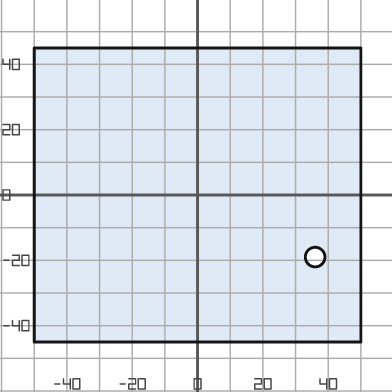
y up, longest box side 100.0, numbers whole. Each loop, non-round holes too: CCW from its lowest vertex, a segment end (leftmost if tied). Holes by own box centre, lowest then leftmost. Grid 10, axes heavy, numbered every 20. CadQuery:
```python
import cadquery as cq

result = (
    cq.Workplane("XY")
    .moveTo(-50.0, -45.0)
    .lineTo(50.0, -45.0)
    .lineTo(50.0, 45.0)
    .lineTo(-50.0, 45.0)
    .close()
    .moveTo(36.0, -19.0)
    .circle(3.0)
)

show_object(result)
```